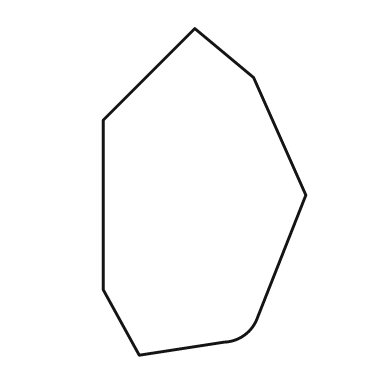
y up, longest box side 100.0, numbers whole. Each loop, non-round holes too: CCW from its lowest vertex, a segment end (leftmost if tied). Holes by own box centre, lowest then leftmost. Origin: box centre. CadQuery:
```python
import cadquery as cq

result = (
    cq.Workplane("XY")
    .moveTo(-20.0, -50.0)
    .lineTo(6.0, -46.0)
    .threePointArc((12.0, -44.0), (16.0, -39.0))
    .lineTo(31.0, -1.0)
    .lineTo(15.0, 35.0)
    .lineTo(-3.0, 50.0)
    .lineTo(-31.0, 22.0)
    .lineTo(-31.0, -30.0)
    .close()
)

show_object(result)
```